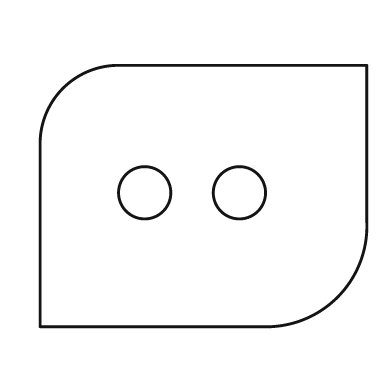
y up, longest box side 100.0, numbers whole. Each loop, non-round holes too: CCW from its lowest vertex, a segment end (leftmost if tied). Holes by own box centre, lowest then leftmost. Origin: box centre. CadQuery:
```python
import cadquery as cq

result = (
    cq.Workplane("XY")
    .moveTo(-50.0, -40.0)
    .lineTo(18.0, -40.0)
    .threePointArc((41.0, -31.0), (50.0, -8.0))
    .lineTo(50.0, 40.0)
    .lineTo(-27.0, 40.0)
    .threePointArc((-43.0, 33.0), (-50.0, 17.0))
    .close()
    .moveTo(-18.0, 1.0)
    .circle(8.0)
    .moveTo(11.0, 1.0)
    .circle(8.0)
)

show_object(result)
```